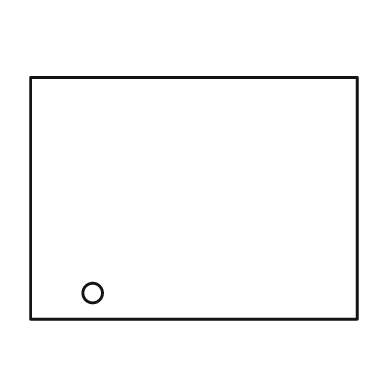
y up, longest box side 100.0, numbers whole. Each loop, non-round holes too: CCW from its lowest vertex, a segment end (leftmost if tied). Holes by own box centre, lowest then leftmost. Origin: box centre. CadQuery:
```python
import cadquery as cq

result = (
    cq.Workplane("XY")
    .moveTo(-50.0, -37.0)
    .lineTo(50.0, -37.0)
    .lineTo(50.0, 37.0)
    .lineTo(-50.0, 37.0)
    .close()
    .moveTo(-31.0, -29.0)
    .circle(3.0)
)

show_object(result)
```